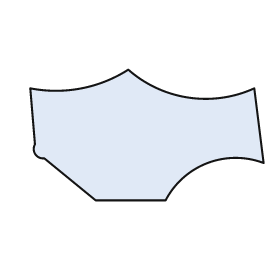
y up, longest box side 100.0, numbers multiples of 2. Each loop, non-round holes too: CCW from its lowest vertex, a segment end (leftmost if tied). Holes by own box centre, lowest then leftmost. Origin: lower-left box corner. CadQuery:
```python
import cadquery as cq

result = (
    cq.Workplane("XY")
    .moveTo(28.0, 0.0)
    .lineTo(58.0, 0.0)
    .threePointArc((76.0, 16.0), (100.0, 16.0))
    .lineTo(96.0, 48.0)
    .threePointArc((68.0, 44.0), (42.0, 56.0))
    .threePointArc((22.0, 48.0), (0.0, 48.0))
    .lineTo(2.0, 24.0)
    .threePointArc((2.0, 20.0), (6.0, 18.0))
    .close()
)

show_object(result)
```